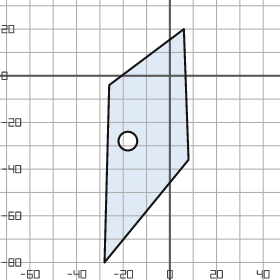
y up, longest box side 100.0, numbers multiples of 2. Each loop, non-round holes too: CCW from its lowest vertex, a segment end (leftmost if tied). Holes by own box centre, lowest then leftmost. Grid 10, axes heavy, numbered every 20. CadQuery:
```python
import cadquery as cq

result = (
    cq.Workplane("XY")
    .moveTo(-28.0, -80.0)
    .lineTo(8.0, -36.0)
    .lineTo(6.0, 20.0)
    .lineTo(-26.0, -4.0)
    .close()
    .moveTo(-18.0, -28.0)
    .circle(4.0)
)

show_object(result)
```